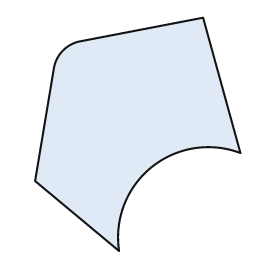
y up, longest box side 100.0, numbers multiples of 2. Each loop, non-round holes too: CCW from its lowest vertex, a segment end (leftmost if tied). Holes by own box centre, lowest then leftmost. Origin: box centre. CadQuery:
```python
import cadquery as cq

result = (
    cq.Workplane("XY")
    .moveTo(-8.0, -50.0)
    .threePointArc((6.0, -14.0), (44.0, -8.0))
    .lineTo(28.0, 50.0)
    .lineTo(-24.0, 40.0)
    .threePointArc((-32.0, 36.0), (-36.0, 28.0))
    .lineTo(-44.0, -20.0)
    .close()
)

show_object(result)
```